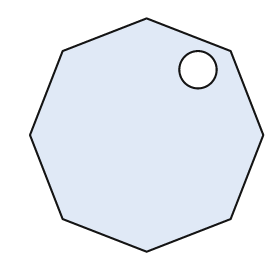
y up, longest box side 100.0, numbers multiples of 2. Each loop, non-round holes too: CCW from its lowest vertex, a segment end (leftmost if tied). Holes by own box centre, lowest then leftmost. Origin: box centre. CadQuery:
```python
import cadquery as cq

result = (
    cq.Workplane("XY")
    .moveTo(0.0, -50.0)
    .lineTo(36.0, -36.0)
    .lineTo(50.0, 0.0)
    .lineTo(36.0, 36.0)
    .lineTo(0.0, 50.0)
    .lineTo(-36.0, 36.0)
    .lineTo(-50.0, 0.0)
    .lineTo(-36.0, -36.0)
    .close()
    .moveTo(22.0, 28.0)
    .circle(8.0)
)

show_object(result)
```